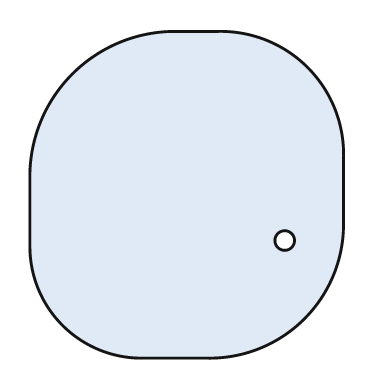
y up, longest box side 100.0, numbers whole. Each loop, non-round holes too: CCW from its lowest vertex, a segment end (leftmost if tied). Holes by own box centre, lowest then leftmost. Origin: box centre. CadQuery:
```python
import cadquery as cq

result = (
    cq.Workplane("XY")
    .moveTo(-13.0, -50.0)
    .lineTo(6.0, -50.0)
    .threePointArc((36.0, -38.0), (48.0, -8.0))
    .lineTo(48.0, 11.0)
    .threePointArc((37.0, 39.0), (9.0, 50.0))
    .lineTo(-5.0, 50.0)
    .threePointArc((-35.0, 37.0), (-48.0, 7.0))
    .lineTo(-48.0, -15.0)
    .threePointArc((-38.0, -40.0), (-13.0, -50.0))
    .close()
    .moveTo(30.0, -14.0)
    .circle(3.0)
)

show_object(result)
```